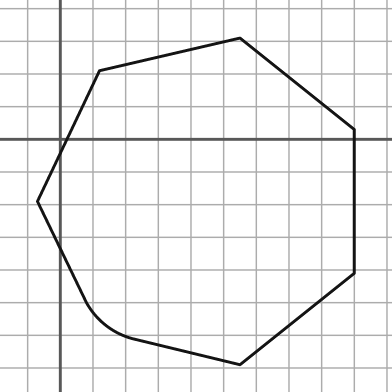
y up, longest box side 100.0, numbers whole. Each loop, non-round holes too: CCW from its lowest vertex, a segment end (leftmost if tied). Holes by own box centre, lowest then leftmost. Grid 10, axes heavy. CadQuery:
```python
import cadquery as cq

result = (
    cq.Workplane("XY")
    .moveTo(55.0, -69.0)
    .lineTo(90.0, -41.0)
    .lineTo(90.0, 3.0)
    .lineTo(55.0, 31.0)
    .lineTo(12.0, 21.0)
    .lineTo(-7.0, -19.0)
    .lineTo(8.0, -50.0)
    .threePointArc((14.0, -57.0), (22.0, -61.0))
    .close()
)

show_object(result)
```